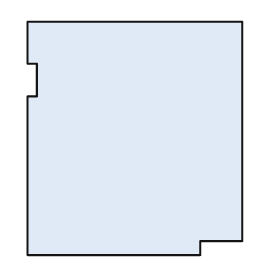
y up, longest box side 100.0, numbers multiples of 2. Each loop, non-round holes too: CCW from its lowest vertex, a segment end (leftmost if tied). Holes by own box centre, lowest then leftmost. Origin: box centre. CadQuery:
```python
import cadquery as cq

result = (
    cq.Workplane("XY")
    .moveTo(-46.0, -50.0)
    .lineTo(28.0, -50.0)
    .lineTo(28.0, -44.0)
    .lineTo(46.0, -44.0)
    .lineTo(46.0, 50.0)
    .lineTo(-46.0, 50.0)
    .lineTo(-46.0, 32.0)
    .lineTo(-42.0, 32.0)
    .lineTo(-42.0, 18.0)
    .lineTo(-46.0, 18.0)
    .close()
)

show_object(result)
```